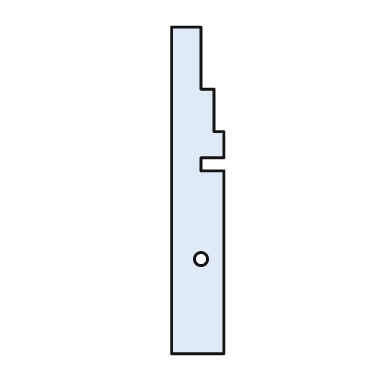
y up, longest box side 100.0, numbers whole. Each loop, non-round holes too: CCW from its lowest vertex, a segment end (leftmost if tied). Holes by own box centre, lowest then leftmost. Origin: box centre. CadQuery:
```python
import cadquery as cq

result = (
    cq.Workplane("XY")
    .moveTo(-8.0, -50.0)
    .lineTo(8.0, -50.0)
    .lineTo(8.0, 6.0)
    .lineTo(1.0, 6.0)
    .lineTo(1.0, 10.0)
    .lineTo(8.0, 10.0)
    .lineTo(8.0, 18.0)
    .lineTo(5.0, 18.0)
    .lineTo(5.0, 31.0)
    .lineTo(1.0, 31.0)
    .lineTo(1.0, 50.0)
    .lineTo(-8.0, 50.0)
    .close()
    .moveTo(1.0, -21.0)
    .circle(2.0)
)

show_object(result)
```